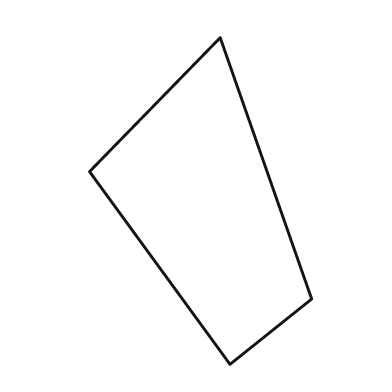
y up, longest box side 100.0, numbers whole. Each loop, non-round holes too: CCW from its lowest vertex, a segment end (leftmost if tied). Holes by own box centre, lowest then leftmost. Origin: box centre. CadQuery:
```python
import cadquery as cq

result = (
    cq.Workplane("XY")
    .moveTo(9.0, -50.0)
    .lineTo(34.0, -30.0)
    .lineTo(6.0, 50.0)
    .lineTo(-34.0, 9.0)
    .close()
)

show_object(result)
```